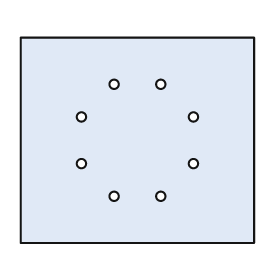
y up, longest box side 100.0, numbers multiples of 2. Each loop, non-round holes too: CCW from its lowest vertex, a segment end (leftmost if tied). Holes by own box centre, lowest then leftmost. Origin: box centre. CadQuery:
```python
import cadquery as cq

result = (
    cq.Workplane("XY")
    .moveTo(-50.0, -44.0)
    .lineTo(50.0, -44.0)
    .lineTo(50.0, 44.0)
    .lineTo(-50.0, 44.0)
    .close()
    .moveTo(-10.0, -24.0)
    .circle(2.0)
    .moveTo(10.0, -24.0)
    .circle(2.0)
    .moveTo(-24.0, -10.0)
    .circle(2.0)
    .moveTo(24.0, -10.0)
    .circle(2.0)
    .moveTo(-24.0, 10.0)
    .circle(2.0)
    .moveTo(24.0, 10.0)
    .circle(2.0)
    .moveTo(-10.0, 24.0)
    .circle(2.0)
    .moveTo(10.0, 24.0)
    .circle(2.0)
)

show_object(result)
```